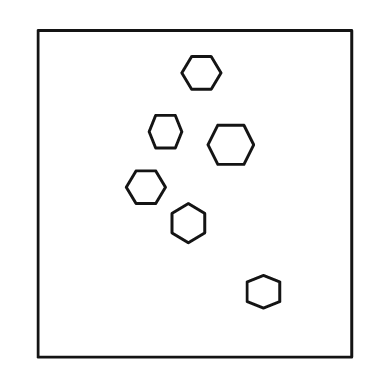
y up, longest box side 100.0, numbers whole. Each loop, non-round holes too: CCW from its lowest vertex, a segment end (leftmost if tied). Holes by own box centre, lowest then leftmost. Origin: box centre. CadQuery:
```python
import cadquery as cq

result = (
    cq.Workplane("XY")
    .moveTo(-48.0, -50.0)
    .lineTo(48.0, -50.0)
    .lineTo(48.0, 50.0)
    .lineTo(-48.0, 50.0)
    .close()
    .moveTo(21.0, -35.0)
    .lineTo(26.0, -33.0)
    .lineTo(26.0, -27.0)
    .lineTo(21.0, -25.0)
    .lineTo(16.0, -27.0)
    .lineTo(16.0, -33.0)
    .close()
    .moveTo(-2.0, -15.0)
    .lineTo(3.0, -12.0)
    .lineTo(3.0, -6.0)
    .lineTo(-2.0, -3.0)
    .lineTo(-7.0, -6.0)
    .lineTo(-7.0, -12.0)
    .close()
    .moveTo(-18.0, -3.0)
    .lineTo(-12.0, -3.0)
    .lineTo(-9.0, 2.0)
    .lineTo(-12.0, 7.0)
    .lineTo(-18.0, 7.0)
    .lineTo(-21.0, 2.0)
    .close()
    .moveTo(7.0, 9.0)
    .lineTo(15.0, 9.0)
    .lineTo(18.0, 15.0)
    .lineTo(15.0, 21.0)
    .lineTo(7.0, 21.0)
    .lineTo(4.0, 15.0)
    .close()
    .moveTo(-12.0, 14.0)
    .lineTo(-6.0, 14.0)
    .lineTo(-4.0, 19.0)
    .lineTo(-6.0, 24.0)
    .lineTo(-12.0, 24.0)
    .lineTo(-14.0, 19.0)
    .close()
    .moveTo(-1.0, 32.0)
    .lineTo(5.0, 32.0)
    .lineTo(8.0, 37.0)
    .lineTo(5.0, 42.0)
    .lineTo(-1.0, 42.0)
    .lineTo(-4.0, 37.0)
    .close()
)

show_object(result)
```